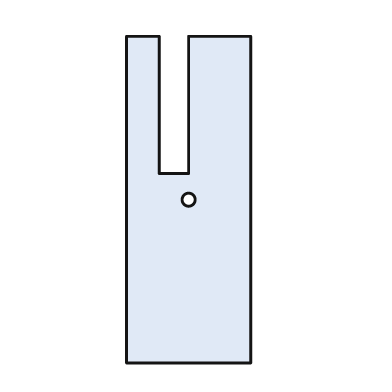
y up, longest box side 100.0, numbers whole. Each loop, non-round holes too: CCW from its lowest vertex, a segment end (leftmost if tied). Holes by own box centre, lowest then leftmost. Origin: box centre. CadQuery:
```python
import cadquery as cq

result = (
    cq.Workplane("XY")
    .moveTo(-19.0, -50.0)
    .lineTo(19.0, -50.0)
    .lineTo(19.0, 50.0)
    .lineTo(0.0, 50.0)
    .lineTo(0.0, 8.0)
    .lineTo(-9.0, 8.0)
    .lineTo(-9.0, 50.0)
    .lineTo(-19.0, 50.0)
    .close()
    .moveTo(0.0, 0.0)
    .circle(2.0)
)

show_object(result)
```